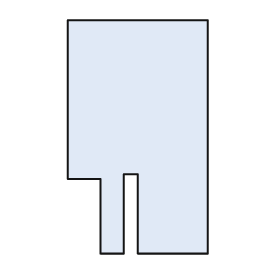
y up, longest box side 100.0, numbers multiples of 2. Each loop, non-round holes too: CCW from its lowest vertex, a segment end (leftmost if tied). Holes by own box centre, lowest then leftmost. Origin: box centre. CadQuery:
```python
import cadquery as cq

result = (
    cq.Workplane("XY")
    .moveTo(-16.0, -50.0)
    .lineTo(-6.0, -50.0)
    .lineTo(-6.0, -16.0)
    .lineTo(0.0, -16.0)
    .lineTo(0.0, -50.0)
    .lineTo(30.0, -50.0)
    .lineTo(30.0, 50.0)
    .lineTo(-30.0, 50.0)
    .lineTo(-30.0, -18.0)
    .lineTo(-16.0, -18.0)
    .close()
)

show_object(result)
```